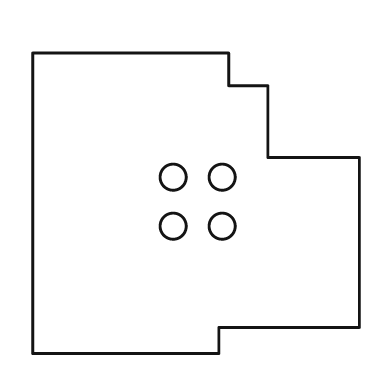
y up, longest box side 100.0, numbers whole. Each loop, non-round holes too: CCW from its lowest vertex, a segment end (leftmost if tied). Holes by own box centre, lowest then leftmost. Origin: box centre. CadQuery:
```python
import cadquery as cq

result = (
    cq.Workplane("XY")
    .moveTo(-50.0, -46.0)
    .lineTo(7.0, -46.0)
    .lineTo(7.0, -38.0)
    .lineTo(50.0, -38.0)
    .lineTo(50.0, 14.0)
    .lineTo(22.0, 14.0)
    .lineTo(22.0, 36.0)
    .lineTo(10.0, 36.0)
    .lineTo(10.0, 46.0)
    .lineTo(-50.0, 46.0)
    .close()
    .moveTo(-7.0, -7.0)
    .circle(4.0)
    .moveTo(8.0, -7.0)
    .circle(4.0)
    .moveTo(-7.0, 8.0)
    .circle(4.0)
    .moveTo(8.0, 8.0)
    .circle(4.0)
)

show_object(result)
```